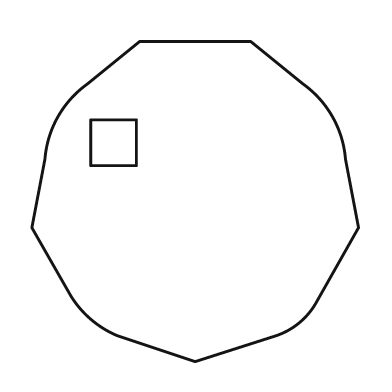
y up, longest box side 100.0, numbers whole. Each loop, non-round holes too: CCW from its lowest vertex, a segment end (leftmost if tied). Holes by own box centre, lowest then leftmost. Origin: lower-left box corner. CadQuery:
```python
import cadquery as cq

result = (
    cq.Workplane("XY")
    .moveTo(50.0, 0.0)
    .lineTo(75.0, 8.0)
    .threePointArc((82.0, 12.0), (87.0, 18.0))
    .lineTo(100.0, 41.0)
    .lineTo(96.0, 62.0)
    .threePointArc((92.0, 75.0), (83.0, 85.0))
    .lineTo(67.0, 98.0)
    .lineTo(33.0, 98.0)
    .lineTo(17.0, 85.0)
    .threePointArc((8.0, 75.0), (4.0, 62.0))
    .lineTo(0.0, 41.0)
    .lineTo(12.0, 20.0)
    .threePointArc((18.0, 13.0), (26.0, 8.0))
    .close()
    .moveTo(18.0, 60.0)
    .lineTo(32.0, 60.0)
    .lineTo(32.0, 74.0)
    .lineTo(18.0, 74.0)
    .close()
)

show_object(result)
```